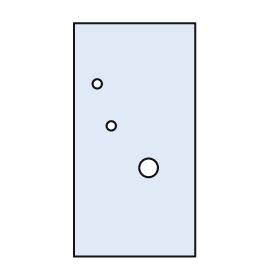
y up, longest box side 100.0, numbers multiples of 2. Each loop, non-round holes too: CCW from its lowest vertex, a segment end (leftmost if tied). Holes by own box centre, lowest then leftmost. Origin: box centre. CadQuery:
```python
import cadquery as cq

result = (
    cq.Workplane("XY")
    .moveTo(-26.0, -50.0)
    .lineTo(26.0, -50.0)
    .lineTo(26.0, 50.0)
    .lineTo(-26.0, 50.0)
    .close()
    .moveTo(6.0, -12.0)
    .circle(4.0)
    .moveTo(-10.0, 6.0)
    .circle(2.0)
    .moveTo(-16.0, 24.0)
    .circle(2.0)
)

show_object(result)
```